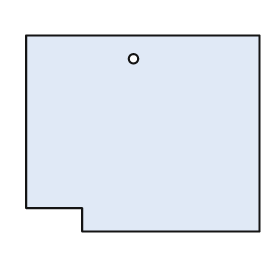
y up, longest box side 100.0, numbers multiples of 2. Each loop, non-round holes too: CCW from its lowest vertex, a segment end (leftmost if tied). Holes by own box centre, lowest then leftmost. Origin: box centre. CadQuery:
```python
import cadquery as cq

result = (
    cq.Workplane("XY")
    .moveTo(-26.0, -42.0)
    .lineTo(50.0, -42.0)
    .lineTo(50.0, 42.0)
    .lineTo(-50.0, 42.0)
    .lineTo(-50.0, -32.0)
    .lineTo(-26.0, -32.0)
    .close()
    .moveTo(-4.0, 32.0)
    .circle(2.0)
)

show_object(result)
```